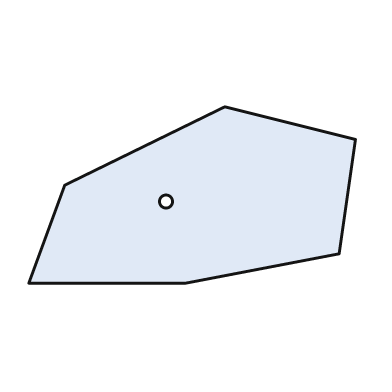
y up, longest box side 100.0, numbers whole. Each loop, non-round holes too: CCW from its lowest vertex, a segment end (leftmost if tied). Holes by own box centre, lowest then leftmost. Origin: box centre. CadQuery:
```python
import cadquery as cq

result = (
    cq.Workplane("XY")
    .moveTo(-50.0, -27.0)
    .lineTo(-2.0, -27.0)
    .lineTo(45.0, -18.0)
    .lineTo(50.0, 17.0)
    .lineTo(10.0, 27.0)
    .lineTo(-39.0, 3.0)
    .close()
    .moveTo(-8.0, -2.0)
    .circle(2.0)
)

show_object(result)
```